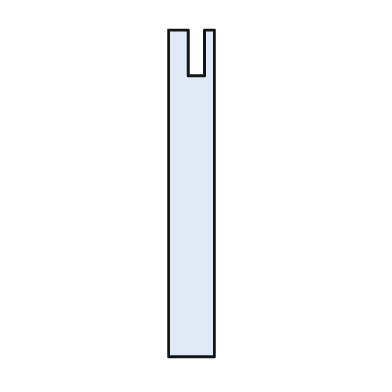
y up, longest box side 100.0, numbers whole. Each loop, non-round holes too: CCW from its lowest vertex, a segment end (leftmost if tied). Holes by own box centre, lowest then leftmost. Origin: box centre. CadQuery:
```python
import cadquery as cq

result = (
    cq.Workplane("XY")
    .moveTo(-7.0, -50.0)
    .lineTo(7.0, -50.0)
    .lineTo(7.0, 50.0)
    .lineTo(4.0, 50.0)
    .lineTo(4.0, 36.0)
    .lineTo(-1.0, 36.0)
    .lineTo(-1.0, 50.0)
    .lineTo(-7.0, 50.0)
    .close()
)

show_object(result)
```